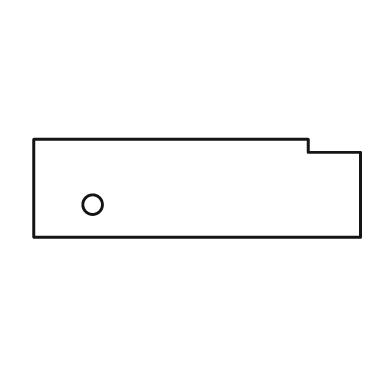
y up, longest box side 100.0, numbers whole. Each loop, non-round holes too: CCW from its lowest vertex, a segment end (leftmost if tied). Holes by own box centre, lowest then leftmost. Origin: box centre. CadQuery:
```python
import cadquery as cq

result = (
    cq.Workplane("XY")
    .moveTo(-50.0, -15.0)
    .lineTo(50.0, -15.0)
    .lineTo(50.0, 11.0)
    .lineTo(34.0, 11.0)
    .lineTo(34.0, 15.0)
    .lineTo(-50.0, 15.0)
    .close()
    .moveTo(-32.0, -5.0)
    .circle(3.0)
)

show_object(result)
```